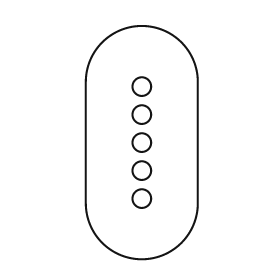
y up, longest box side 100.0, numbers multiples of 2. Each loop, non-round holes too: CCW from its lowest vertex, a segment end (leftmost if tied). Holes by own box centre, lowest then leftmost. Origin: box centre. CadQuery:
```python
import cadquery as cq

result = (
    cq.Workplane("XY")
    .moveTo(-24.0, -26.0)
    .threePointArc((0.0, -50.0), (24.0, -26.0))
    .lineTo(24.0, 26.0)
    .threePointArc((0.0, 50.0), (-24.0, 26.0))
    .close()
    .moveTo(0.0, -24.0)
    .circle(4.0)
    .moveTo(0.0, -12.0)
    .circle(4.0)
    .moveTo(0.0, 0.0)
    .circle(4.0)
    .moveTo(0.0, 12.0)
    .circle(4.0)
    .moveTo(0.0, 24.0)
    .circle(4.0)
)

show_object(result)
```